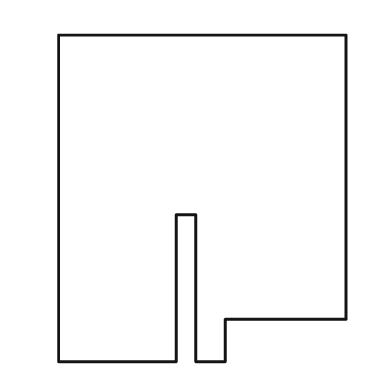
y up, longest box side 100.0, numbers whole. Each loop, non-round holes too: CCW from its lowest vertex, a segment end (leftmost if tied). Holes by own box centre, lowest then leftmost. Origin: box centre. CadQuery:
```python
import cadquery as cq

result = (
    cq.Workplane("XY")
    .moveTo(-44.0, -50.0)
    .lineTo(-8.0, -50.0)
    .lineTo(-8.0, -5.0)
    .lineTo(-2.0, -5.0)
    .lineTo(-2.0, -50.0)
    .lineTo(7.0, -50.0)
    .lineTo(7.0, -37.0)
    .lineTo(44.0, -37.0)
    .lineTo(44.0, 50.0)
    .lineTo(-44.0, 50.0)
    .close()
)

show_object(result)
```